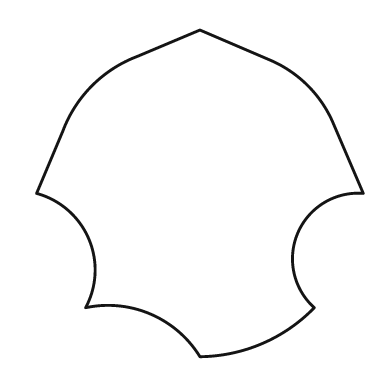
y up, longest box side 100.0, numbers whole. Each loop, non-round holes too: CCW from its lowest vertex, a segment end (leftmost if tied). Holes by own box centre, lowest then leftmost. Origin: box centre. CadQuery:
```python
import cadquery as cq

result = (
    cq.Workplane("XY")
    .moveTo(0.0, -50.0)
    .threePointArc((19.0, -46.0), (35.0, -35.0))
    .threePointArc((30.0, -12.0), (50.0, 0.0))
    .lineTo(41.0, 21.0)
    .threePointArc((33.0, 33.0), (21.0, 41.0))
    .lineTo(0.0, 50.0)
    .lineTo(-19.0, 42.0)
    .threePointArc((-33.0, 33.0), (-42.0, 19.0))
    .lineTo(-50.0, 0.0)
    .threePointArc((-34.0, -14.0), (-35.0, -35.0))
    .threePointArc((-15.0, -37.0), (0.0, -50.0))
    .close()
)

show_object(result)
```